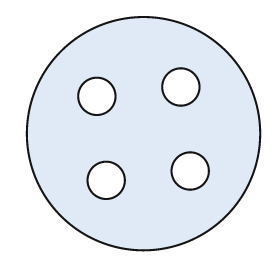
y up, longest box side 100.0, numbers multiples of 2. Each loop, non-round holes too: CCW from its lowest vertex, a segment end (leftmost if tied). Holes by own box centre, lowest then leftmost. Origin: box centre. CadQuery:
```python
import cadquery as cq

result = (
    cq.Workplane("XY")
    .moveTo(0.0, 0.0)
    .circle(50.0)
    .moveTo(-16.0, -20.0)
    .circle(8.0)
    .moveTo(20.0, -16.0)
    .circle(8.0)
    .moveTo(-20.0, 16.0)
    .circle(8.0)
    .moveTo(16.0, 20.0)
    .circle(8.0)
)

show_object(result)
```